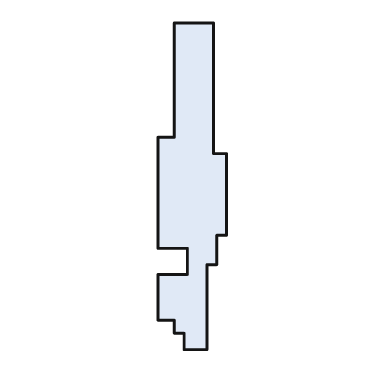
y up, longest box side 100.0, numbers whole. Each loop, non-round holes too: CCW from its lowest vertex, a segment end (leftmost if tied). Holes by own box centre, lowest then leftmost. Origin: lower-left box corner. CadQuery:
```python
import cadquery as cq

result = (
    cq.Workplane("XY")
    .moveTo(8.0, 0.0)
    .lineTo(15.0, 0.0)
    .lineTo(15.0, 26.0)
    .lineTo(18.0, 26.0)
    .lineTo(18.0, 35.0)
    .lineTo(21.0, 35.0)
    .lineTo(21.0, 60.0)
    .lineTo(17.0, 60.0)
    .lineTo(17.0, 100.0)
    .lineTo(5.0, 100.0)
    .lineTo(5.0, 65.0)
    .lineTo(0.0, 65.0)
    .lineTo(0.0, 31.0)
    .lineTo(9.0, 31.0)
    .lineTo(9.0, 23.0)
    .lineTo(0.0, 23.0)
    .lineTo(0.0, 9.0)
    .lineTo(5.0, 9.0)
    .lineTo(5.0, 5.0)
    .lineTo(8.0, 5.0)
    .close()
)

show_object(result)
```